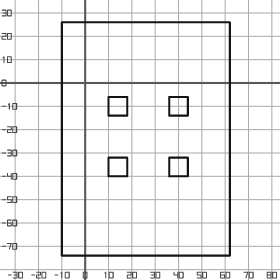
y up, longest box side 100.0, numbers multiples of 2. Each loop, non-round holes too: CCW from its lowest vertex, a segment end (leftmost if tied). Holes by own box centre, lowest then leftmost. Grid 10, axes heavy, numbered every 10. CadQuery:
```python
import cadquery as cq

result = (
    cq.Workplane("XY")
    .moveTo(-10.0, -74.0)
    .lineTo(62.0, -74.0)
    .lineTo(62.0, 26.0)
    .lineTo(-10.0, 26.0)
    .close()
    .moveTo(10.0, -40.0)
    .lineTo(18.0, -40.0)
    .lineTo(18.0, -32.0)
    .lineTo(10.0, -32.0)
    .close()
    .moveTo(36.0, -40.0)
    .lineTo(44.0, -40.0)
    .lineTo(44.0, -32.0)
    .lineTo(36.0, -32.0)
    .close()
    .moveTo(10.0, -14.0)
    .lineTo(18.0, -14.0)
    .lineTo(18.0, -6.0)
    .lineTo(10.0, -6.0)
    .close()
    .moveTo(36.0, -14.0)
    .lineTo(44.0, -14.0)
    .lineTo(44.0, -6.0)
    .lineTo(36.0, -6.0)
    .close()
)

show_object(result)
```